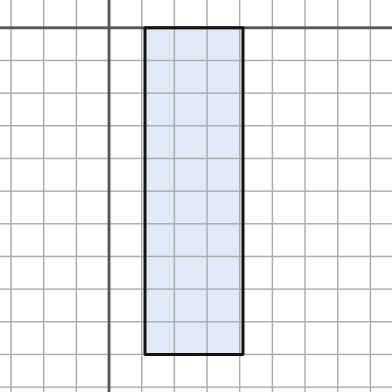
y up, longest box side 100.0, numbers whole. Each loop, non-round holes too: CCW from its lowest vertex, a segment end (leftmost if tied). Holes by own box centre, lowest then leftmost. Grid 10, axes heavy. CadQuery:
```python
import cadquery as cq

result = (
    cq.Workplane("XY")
    .moveTo(11.0, -100.0)
    .lineTo(41.0, -100.0)
    .lineTo(41.0, 0.0)
    .lineTo(11.0, 0.0)
    .close()
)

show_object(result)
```